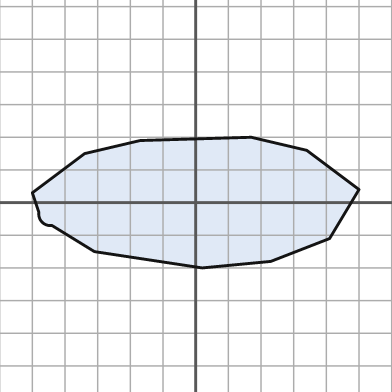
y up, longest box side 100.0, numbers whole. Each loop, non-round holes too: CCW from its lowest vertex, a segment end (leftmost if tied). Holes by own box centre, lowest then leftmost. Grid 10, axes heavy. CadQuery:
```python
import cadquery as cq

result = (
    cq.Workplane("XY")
    .moveTo(2.0, -20.0)
    .lineTo(23.0, -18.0)
    .lineTo(41.0, -11.0)
    .lineTo(50.0, 4.0)
    .lineTo(34.0, 16.0)
    .lineTo(17.0, 20.0)
    .lineTo(-17.0, 19.0)
    .lineTo(-34.0, 15.0)
    .lineTo(-50.0, 3.0)
    .lineTo(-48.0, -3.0)
    .threePointArc((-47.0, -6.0), (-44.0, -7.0))
    .lineTo(-31.0, -15.0)
    .close()
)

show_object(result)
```